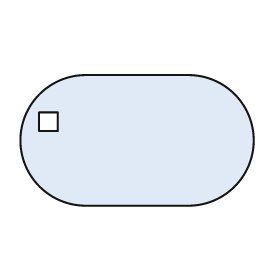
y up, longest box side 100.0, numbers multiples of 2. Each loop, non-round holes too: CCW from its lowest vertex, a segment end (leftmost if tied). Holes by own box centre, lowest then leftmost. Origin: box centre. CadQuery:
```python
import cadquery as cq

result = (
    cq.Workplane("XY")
    .moveTo(-22.0, -28.0)
    .lineTo(22.0, -28.0)
    .threePointArc((50.0, 0.0), (22.0, 28.0))
    .lineTo(-22.0, 28.0)
    .threePointArc((-50.0, 0.0), (-22.0, -28.0))
    .close()
    .moveTo(-42.0, 4.0)
    .lineTo(-34.0, 4.0)
    .lineTo(-34.0, 12.0)
    .lineTo(-42.0, 12.0)
    .close()
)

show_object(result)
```